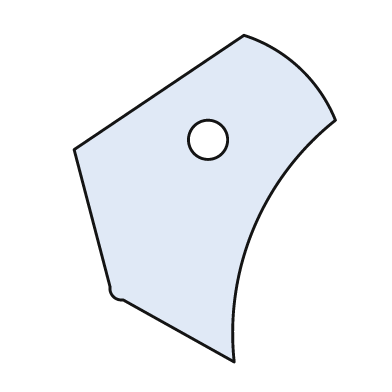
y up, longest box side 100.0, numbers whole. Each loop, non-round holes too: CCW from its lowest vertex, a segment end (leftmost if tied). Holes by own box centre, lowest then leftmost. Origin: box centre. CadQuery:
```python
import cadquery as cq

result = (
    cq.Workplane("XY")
    .moveTo(9.0, -50.0)
    .threePointArc((15.0, -9.0), (40.0, 24.0))
    .threePointArc((29.0, 40.0), (12.0, 50.0))
    .lineTo(-40.0, 15.0)
    .lineTo(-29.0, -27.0)
    .threePointArc((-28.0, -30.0), (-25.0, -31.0))
    .close()
    .moveTo(1.0, 18.0)
    .circle(6.0)
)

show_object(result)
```